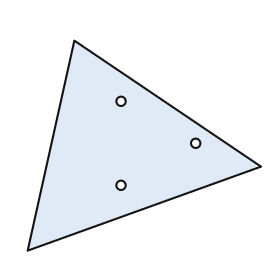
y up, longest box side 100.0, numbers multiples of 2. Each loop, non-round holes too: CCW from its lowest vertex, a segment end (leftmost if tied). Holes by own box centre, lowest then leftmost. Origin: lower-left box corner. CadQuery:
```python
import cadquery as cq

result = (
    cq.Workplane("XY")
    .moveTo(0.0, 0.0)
    .lineTo(100.0, 36.0)
    .lineTo(20.0, 90.0)
    .close()
    .moveTo(40.0, 28.0)
    .circle(2.0)
    .moveTo(72.0, 46.0)
    .circle(2.0)
    .moveTo(40.0, 64.0)
    .circle(2.0)
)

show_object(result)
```